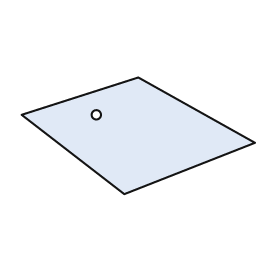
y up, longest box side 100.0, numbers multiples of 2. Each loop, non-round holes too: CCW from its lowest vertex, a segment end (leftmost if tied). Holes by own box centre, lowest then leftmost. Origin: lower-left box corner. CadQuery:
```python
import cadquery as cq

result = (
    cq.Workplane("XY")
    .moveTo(44.0, 0.0)
    .lineTo(100.0, 22.0)
    .lineTo(50.0, 50.0)
    .lineTo(0.0, 34.0)
    .close()
    .moveTo(32.0, 34.0)
    .circle(2.0)
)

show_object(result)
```